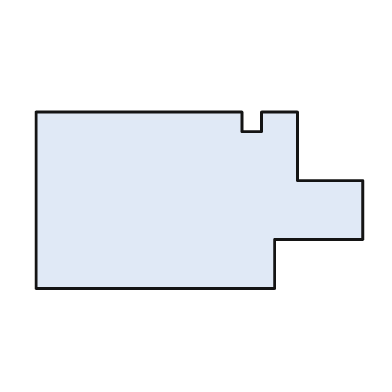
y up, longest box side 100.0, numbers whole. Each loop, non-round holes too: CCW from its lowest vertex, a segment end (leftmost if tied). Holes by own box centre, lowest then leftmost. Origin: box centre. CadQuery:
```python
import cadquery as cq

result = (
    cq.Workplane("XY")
    .moveTo(-50.0, -27.0)
    .lineTo(23.0, -27.0)
    .lineTo(23.0, -12.0)
    .lineTo(50.0, -12.0)
    .lineTo(50.0, 6.0)
    .lineTo(30.0, 6.0)
    .lineTo(30.0, 27.0)
    .lineTo(19.0, 27.0)
    .lineTo(19.0, 21.0)
    .lineTo(13.0, 21.0)
    .lineTo(13.0, 27.0)
    .lineTo(-50.0, 27.0)
    .close()
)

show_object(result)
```